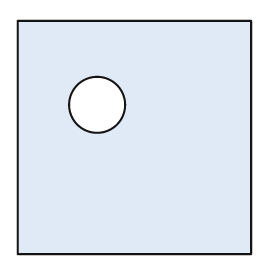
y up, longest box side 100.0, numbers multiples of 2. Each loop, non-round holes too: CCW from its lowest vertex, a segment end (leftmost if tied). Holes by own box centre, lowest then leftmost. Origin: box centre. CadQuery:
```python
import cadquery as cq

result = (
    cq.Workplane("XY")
    .moveTo(-50.0, -50.0)
    .lineTo(50.0, -50.0)
    .lineTo(50.0, 50.0)
    .lineTo(-50.0, 50.0)
    .close()
    .moveTo(-16.0, 14.0)
    .circle(12.0)
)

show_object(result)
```